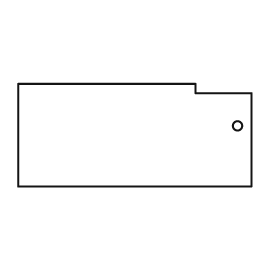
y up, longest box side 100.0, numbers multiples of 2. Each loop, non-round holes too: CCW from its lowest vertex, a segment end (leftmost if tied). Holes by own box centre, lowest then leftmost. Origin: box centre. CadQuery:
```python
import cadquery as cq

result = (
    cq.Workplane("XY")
    .moveTo(-50.0, -22.0)
    .lineTo(50.0, -22.0)
    .lineTo(50.0, 18.0)
    .lineTo(26.0, 18.0)
    .lineTo(26.0, 22.0)
    .lineTo(-50.0, 22.0)
    .close()
    .moveTo(44.0, 4.0)
    .circle(2.0)
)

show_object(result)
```